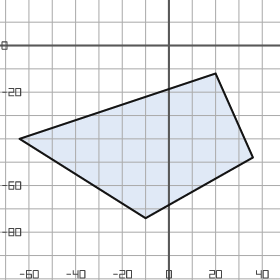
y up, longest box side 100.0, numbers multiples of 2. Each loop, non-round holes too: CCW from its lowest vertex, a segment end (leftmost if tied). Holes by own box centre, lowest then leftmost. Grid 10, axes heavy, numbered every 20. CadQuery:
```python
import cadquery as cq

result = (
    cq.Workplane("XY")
    .moveTo(-10.0, -74.0)
    .lineTo(36.0, -48.0)
    .lineTo(20.0, -12.0)
    .lineTo(-64.0, -40.0)
    .close()
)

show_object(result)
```